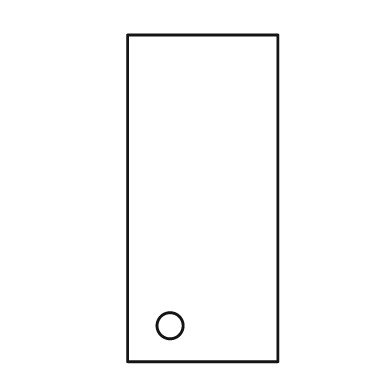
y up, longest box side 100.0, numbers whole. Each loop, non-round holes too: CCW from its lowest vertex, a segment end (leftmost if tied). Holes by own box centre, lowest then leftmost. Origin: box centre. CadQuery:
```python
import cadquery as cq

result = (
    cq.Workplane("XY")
    .moveTo(-23.0, -50.0)
    .lineTo(23.0, -50.0)
    .lineTo(23.0, 50.0)
    .lineTo(-23.0, 50.0)
    .close()
    .moveTo(-10.0, -39.0)
    .circle(4.0)
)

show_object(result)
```